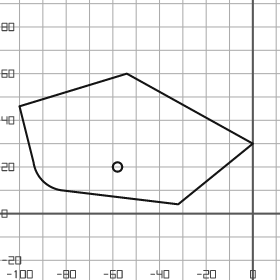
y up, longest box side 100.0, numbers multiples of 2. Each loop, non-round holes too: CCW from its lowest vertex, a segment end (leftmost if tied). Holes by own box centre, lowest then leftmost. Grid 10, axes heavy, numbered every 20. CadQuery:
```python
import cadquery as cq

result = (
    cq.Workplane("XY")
    .moveTo(-32.0, 4.0)
    .lineTo(0.0, 30.0)
    .lineTo(-54.0, 60.0)
    .lineTo(-100.0, 46.0)
    .lineTo(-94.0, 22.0)
    .threePointArc((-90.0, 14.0), (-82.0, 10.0))
    .close()
    .moveTo(-58.0, 20.0)
    .circle(2.0)
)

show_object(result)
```